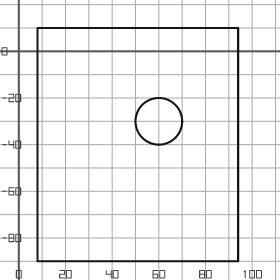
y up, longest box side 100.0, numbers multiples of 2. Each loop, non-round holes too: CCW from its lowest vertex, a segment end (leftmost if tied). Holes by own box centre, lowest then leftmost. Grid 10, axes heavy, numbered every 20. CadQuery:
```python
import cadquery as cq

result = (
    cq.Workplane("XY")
    .moveTo(8.0, -90.0)
    .lineTo(94.0, -90.0)
    .lineTo(94.0, 10.0)
    .lineTo(8.0, 10.0)
    .close()
    .moveTo(60.0, -30.0)
    .circle(10.0)
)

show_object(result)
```